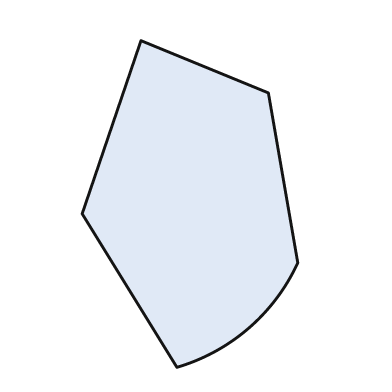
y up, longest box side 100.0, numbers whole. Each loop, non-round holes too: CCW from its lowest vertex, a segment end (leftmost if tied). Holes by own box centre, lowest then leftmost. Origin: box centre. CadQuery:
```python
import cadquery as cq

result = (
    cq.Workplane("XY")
    .moveTo(-4.0, -50.0)
    .threePointArc((18.0, -38.0), (33.0, -18.0))
    .lineTo(24.0, 34.0)
    .lineTo(-15.0, 50.0)
    .lineTo(-33.0, -3.0)
    .close()
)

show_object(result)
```